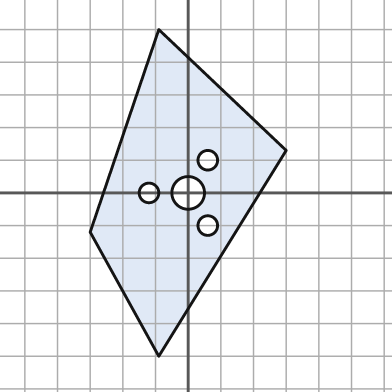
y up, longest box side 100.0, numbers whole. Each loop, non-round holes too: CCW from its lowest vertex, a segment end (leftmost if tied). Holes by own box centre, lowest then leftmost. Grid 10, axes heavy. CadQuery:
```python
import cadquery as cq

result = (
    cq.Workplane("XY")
    .moveTo(-9.0, -50.0)
    .lineTo(30.0, 13.0)
    .lineTo(-9.0, 50.0)
    .lineTo(-30.0, -12.0)
    .close()
    .moveTo(6.0, -10.0)
    .circle(3.0)
    .moveTo(-12.0, 0.0)
    .circle(3.0)
    .moveTo(0.0, 0.0)
    .circle(5.0)
    .moveTo(6.0, 10.0)
    .circle(3.0)
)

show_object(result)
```